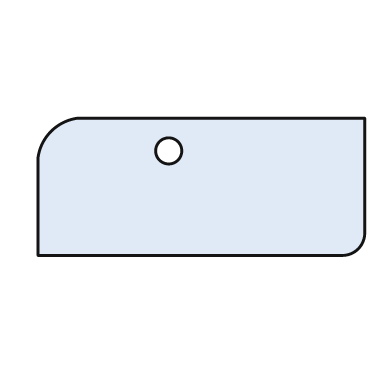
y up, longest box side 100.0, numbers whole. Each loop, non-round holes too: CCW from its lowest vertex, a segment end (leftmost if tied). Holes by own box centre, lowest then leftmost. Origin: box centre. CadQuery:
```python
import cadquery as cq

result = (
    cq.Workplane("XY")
    .moveTo(-50.0, -21.0)
    .lineTo(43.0, -21.0)
    .threePointArc((48.0, -19.0), (50.0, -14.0))
    .lineTo(50.0, 21.0)
    .lineTo(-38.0, 21.0)
    .threePointArc((-46.0, 17.0), (-50.0, 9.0))
    .close()
    .moveTo(-10.0, 11.0)
    .circle(4.0)
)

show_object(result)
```